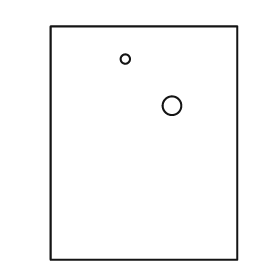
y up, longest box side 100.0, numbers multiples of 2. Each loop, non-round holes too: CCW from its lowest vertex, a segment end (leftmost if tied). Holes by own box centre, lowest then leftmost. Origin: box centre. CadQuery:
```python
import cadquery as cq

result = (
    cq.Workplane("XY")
    .moveTo(-40.0, -50.0)
    .lineTo(40.0, -50.0)
    .lineTo(40.0, 50.0)
    .lineTo(-40.0, 50.0)
    .close()
    .moveTo(12.0, 16.0)
    .circle(4.0)
    .moveTo(-8.0, 36.0)
    .circle(2.0)
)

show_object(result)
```